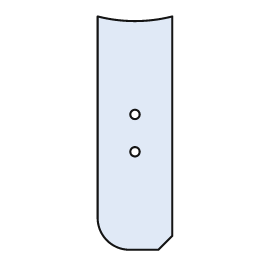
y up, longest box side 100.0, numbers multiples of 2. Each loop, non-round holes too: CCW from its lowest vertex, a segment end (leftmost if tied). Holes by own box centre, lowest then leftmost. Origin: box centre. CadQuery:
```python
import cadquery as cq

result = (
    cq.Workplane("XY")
    .moveTo(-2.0, -50.0)
    .lineTo(10.0, -50.0)
    .lineTo(16.0, -44.0)
    .lineTo(16.0, 50.0)
    .threePointArc((0.0, 48.0), (-16.0, 50.0))
    .lineTo(-16.0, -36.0)
    .threePointArc((-12.0, -46.0), (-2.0, -50.0))
    .close()
    .moveTo(0.0, -8.0)
    .circle(2.0)
    .moveTo(0.0, 8.0)
    .circle(2.0)
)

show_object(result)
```